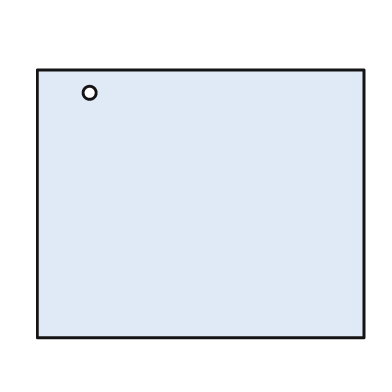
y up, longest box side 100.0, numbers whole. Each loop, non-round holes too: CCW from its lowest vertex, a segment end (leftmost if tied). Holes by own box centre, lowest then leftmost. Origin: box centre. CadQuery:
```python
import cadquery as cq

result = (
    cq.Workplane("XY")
    .moveTo(-50.0, -41.0)
    .lineTo(50.0, -41.0)
    .lineTo(50.0, 41.0)
    .lineTo(-50.0, 41.0)
    .close()
    .moveTo(-34.0, 34.0)
    .circle(2.0)
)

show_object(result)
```